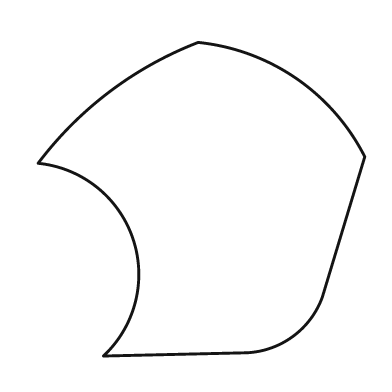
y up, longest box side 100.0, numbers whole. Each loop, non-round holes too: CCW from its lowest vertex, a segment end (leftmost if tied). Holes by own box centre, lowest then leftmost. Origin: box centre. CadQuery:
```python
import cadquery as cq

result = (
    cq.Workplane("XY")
    .moveTo(-30.0, -48.0)
    .lineTo(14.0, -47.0)
    .threePointArc((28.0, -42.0), (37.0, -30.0))
    .lineTo(50.0, 13.0)
    .threePointArc((29.0, 37.0), (-1.0, 48.0))
    .threePointArc((-28.0, 33.0), (-50.0, 11.0))
    .threePointArc((-21.0, -12.0), (-30.0, -48.0))
    .close()
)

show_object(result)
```